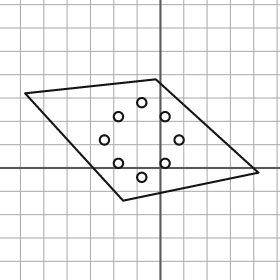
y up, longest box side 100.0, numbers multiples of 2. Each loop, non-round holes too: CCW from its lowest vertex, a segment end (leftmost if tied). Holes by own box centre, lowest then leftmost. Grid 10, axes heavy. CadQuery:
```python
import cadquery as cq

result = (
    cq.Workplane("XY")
    .moveTo(-16.0, -14.0)
    .lineTo(42.0, -2.0)
    .lineTo(-2.0, 38.0)
    .lineTo(-58.0, 32.0)
    .close()
    .moveTo(-8.0, -4.0)
    .circle(2.0)
    .moveTo(-18.0, 2.0)
    .circle(2.0)
    .moveTo(2.0, 2.0)
    .circle(2.0)
    .moveTo(-24.0, 12.0)
    .circle(2.0)
    .moveTo(8.0, 12.0)
    .circle(2.0)
    .moveTo(-18.0, 22.0)
    .circle(2.0)
    .moveTo(2.0, 22.0)
    .circle(2.0)
    .moveTo(-8.0, 28.0)
    .circle(2.0)
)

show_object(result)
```